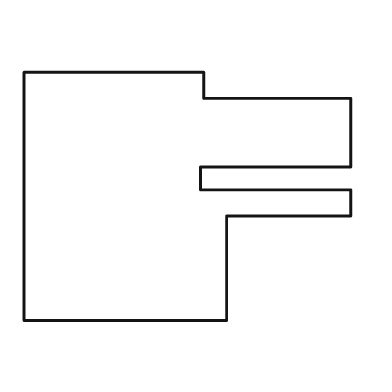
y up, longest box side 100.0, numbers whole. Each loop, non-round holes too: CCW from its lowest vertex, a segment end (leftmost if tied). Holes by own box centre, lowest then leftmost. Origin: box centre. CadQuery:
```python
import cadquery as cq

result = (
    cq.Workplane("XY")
    .moveTo(-50.0, -38.0)
    .lineTo(12.0, -38.0)
    .lineTo(12.0, -6.0)
    .lineTo(50.0, -6.0)
    .lineTo(50.0, 2.0)
    .lineTo(4.0, 2.0)
    .lineTo(4.0, 9.0)
    .lineTo(50.0, 9.0)
    .lineTo(50.0, 30.0)
    .lineTo(5.0, 30.0)
    .lineTo(5.0, 38.0)
    .lineTo(-50.0, 38.0)
    .close()
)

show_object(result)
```